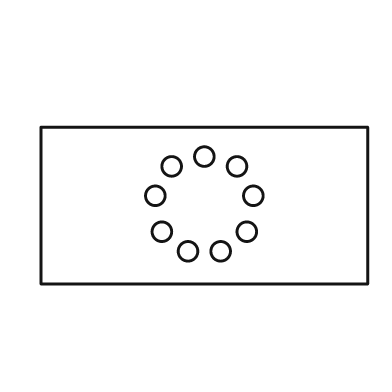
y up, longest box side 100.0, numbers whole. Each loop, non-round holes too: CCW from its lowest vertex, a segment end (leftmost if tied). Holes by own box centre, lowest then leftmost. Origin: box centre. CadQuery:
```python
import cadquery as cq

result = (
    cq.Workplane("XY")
    .moveTo(-50.0, -24.0)
    .lineTo(50.0, -24.0)
    .lineTo(50.0, 24.0)
    .lineTo(-50.0, 24.0)
    .close()
    .moveTo(-5.0, -14.0)
    .circle(3.0)
    .moveTo(5.0, -14.0)
    .circle(3.0)
    .moveTo(-13.0, -8.0)
    .circle(3.0)
    .moveTo(13.0, -8.0)
    .circle(3.0)
    .moveTo(-15.0, 3.0)
    .circle(3.0)
    .moveTo(15.0, 3.0)
    .circle(3.0)
    .moveTo(-10.0, 12.0)
    .circle(3.0)
    .moveTo(10.0, 12.0)
    .circle(3.0)
    .moveTo(0.0, 15.0)
    .circle(3.0)
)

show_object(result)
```